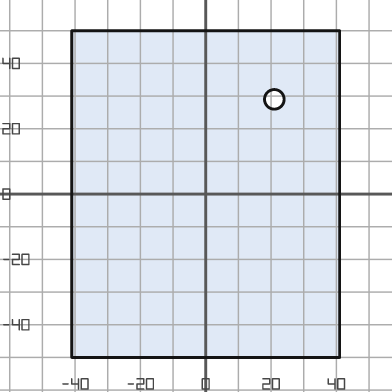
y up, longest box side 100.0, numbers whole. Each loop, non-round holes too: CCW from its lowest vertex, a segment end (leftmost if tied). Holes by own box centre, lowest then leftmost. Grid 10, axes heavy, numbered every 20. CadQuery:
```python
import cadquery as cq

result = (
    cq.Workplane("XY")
    .moveTo(-41.0, -50.0)
    .lineTo(41.0, -50.0)
    .lineTo(41.0, 50.0)
    .lineTo(-41.0, 50.0)
    .close()
    .moveTo(21.0, 29.0)
    .circle(3.0)
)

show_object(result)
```